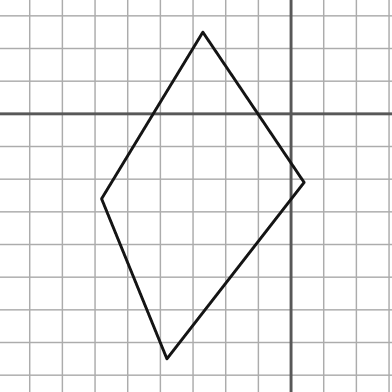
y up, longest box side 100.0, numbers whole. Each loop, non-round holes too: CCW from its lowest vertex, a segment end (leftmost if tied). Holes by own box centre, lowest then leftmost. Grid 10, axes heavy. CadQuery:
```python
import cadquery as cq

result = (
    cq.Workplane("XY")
    .moveTo(-38.0, -75.0)
    .lineTo(4.0, -21.0)
    .lineTo(-27.0, 25.0)
    .lineTo(-58.0, -26.0)
    .close()
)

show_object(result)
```